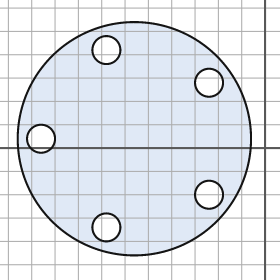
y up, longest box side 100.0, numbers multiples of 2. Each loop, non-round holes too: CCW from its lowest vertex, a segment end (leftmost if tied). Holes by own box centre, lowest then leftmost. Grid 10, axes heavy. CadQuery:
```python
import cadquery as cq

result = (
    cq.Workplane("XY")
    .moveTo(-56.0, 4.0)
    .circle(50.0)
    .moveTo(-68.0, -34.0)
    .circle(6.0)
    .moveTo(-24.0, -20.0)
    .circle(6.0)
    .moveTo(-96.0, 4.0)
    .circle(6.0)
    .moveTo(-24.0, 28.0)
    .circle(6.0)
    .moveTo(-68.0, 42.0)
    .circle(6.0)
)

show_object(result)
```